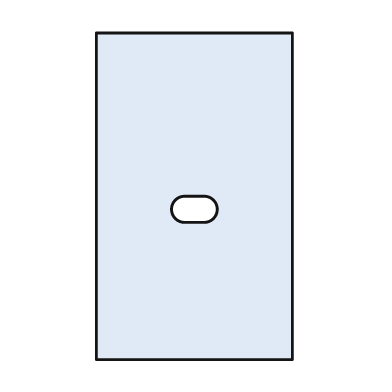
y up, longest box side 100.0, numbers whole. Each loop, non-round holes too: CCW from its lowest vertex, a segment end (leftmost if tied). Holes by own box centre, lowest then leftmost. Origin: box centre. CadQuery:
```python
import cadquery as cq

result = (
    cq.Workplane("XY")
    .moveTo(-30.0, -50.0)
    .lineTo(30.0, -50.0)
    .lineTo(30.0, 50.0)
    .lineTo(-30.0, 50.0)
    .close()
    .moveTo(-3.0, -8.0)
    .lineTo(3.0, -8.0)
    .threePointArc((7.0, -4.0), (3.0, 0.0))
    .lineTo(-3.0, 0.0)
    .threePointArc((-7.0, -4.0), (-3.0, -8.0))
    .close()
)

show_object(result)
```